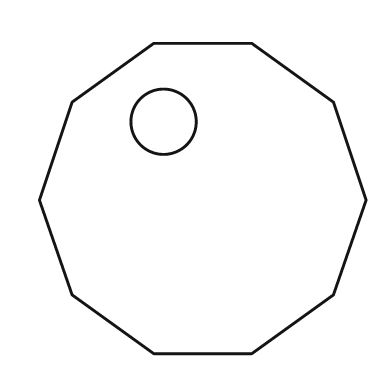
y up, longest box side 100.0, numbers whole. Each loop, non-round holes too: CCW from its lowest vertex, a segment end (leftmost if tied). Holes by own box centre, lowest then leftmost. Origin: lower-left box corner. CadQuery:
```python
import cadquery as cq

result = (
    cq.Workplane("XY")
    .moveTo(35.0, 0.0)
    .lineTo(65.0, 0.0)
    .lineTo(90.0, 18.0)
    .lineTo(100.0, 47.0)
    .lineTo(90.0, 77.0)
    .lineTo(65.0, 95.0)
    .lineTo(35.0, 95.0)
    .lineTo(10.0, 77.0)
    .lineTo(0.0, 47.0)
    .lineTo(10.0, 18.0)
    .close()
    .moveTo(38.0, 71.0)
    .circle(10.0)
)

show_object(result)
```